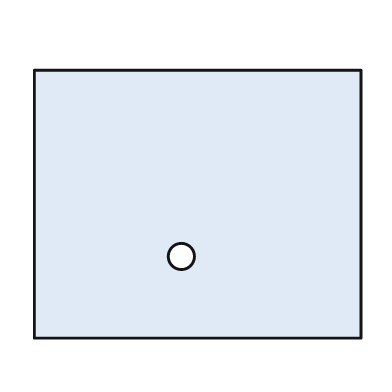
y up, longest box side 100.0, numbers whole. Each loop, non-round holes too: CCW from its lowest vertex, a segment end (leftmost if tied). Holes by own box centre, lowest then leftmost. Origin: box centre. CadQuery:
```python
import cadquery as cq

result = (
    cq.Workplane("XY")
    .moveTo(-50.0, -41.0)
    .lineTo(50.0, -41.0)
    .lineTo(50.0, 41.0)
    .lineTo(-50.0, 41.0)
    .close()
    .moveTo(-5.0, -16.0)
    .circle(4.0)
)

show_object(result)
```